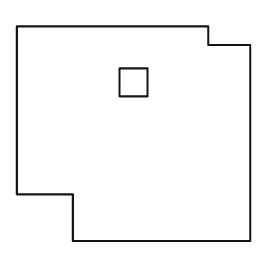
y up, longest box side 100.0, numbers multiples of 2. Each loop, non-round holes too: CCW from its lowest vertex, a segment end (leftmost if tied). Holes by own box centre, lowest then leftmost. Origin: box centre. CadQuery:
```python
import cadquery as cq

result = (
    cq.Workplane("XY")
    .moveTo(-26.0, -46.0)
    .lineTo(50.0, -46.0)
    .lineTo(50.0, 38.0)
    .lineTo(32.0, 38.0)
    .lineTo(32.0, 46.0)
    .lineTo(-50.0, 46.0)
    .lineTo(-50.0, -26.0)
    .lineTo(-26.0, -26.0)
    .close()
    .moveTo(-6.0, 16.0)
    .lineTo(6.0, 16.0)
    .lineTo(6.0, 28.0)
    .lineTo(-6.0, 28.0)
    .close()
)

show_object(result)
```